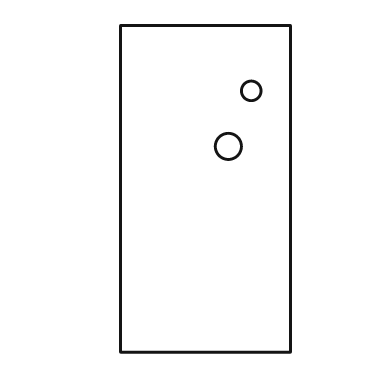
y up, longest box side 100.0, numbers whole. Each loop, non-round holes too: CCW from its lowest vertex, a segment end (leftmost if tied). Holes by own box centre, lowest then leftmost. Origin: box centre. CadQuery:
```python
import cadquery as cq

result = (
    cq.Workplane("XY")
    .moveTo(-26.0, -50.0)
    .lineTo(26.0, -50.0)
    .lineTo(26.0, 50.0)
    .lineTo(-26.0, 50.0)
    .close()
    .moveTo(7.0, 13.0)
    .circle(4.0)
    .moveTo(14.0, 30.0)
    .circle(3.0)
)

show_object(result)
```